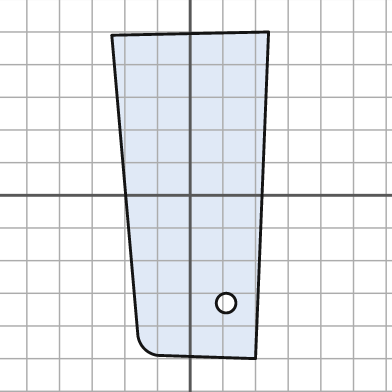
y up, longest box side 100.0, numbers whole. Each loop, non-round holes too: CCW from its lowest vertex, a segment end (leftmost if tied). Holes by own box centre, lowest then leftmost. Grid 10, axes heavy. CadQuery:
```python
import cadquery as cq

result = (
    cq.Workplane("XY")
    .moveTo(20.0, -50.0)
    .lineTo(24.0, 50.0)
    .lineTo(-24.0, 49.0)
    .lineTo(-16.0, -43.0)
    .threePointArc((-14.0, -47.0), (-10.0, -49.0))
    .close()
    .moveTo(11.0, -33.0)
    .circle(3.0)
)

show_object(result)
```